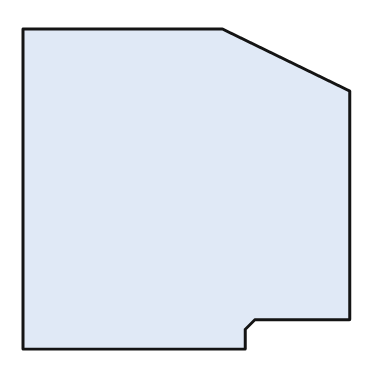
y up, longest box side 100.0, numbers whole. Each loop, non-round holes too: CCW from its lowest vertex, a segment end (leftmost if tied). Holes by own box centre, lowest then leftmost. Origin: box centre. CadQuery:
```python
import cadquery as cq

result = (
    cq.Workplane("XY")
    .moveTo(-50.0, -49.0)
    .lineTo(18.0, -49.0)
    .lineTo(18.0, -43.0)
    .lineTo(21.0, -40.0)
    .lineTo(50.0, -40.0)
    .lineTo(50.0, 30.0)
    .lineTo(11.0, 49.0)
    .lineTo(-50.0, 49.0)
    .close()
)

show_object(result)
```